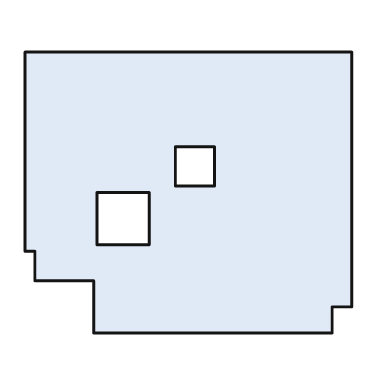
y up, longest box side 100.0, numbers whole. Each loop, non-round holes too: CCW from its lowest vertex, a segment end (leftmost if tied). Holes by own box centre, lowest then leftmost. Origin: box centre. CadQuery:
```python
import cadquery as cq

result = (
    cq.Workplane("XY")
    .moveTo(-29.0, -43.0)
    .lineTo(44.0, -43.0)
    .lineTo(44.0, -35.0)
    .lineTo(50.0, -35.0)
    .lineTo(50.0, 43.0)
    .lineTo(-50.0, 43.0)
    .lineTo(-50.0, -18.0)
    .lineTo(-47.0, -18.0)
    .lineTo(-47.0, -27.0)
    .lineTo(-29.0, -27.0)
    .close()
    .moveTo(-28.0, -16.0)
    .lineTo(-12.0, -16.0)
    .lineTo(-12.0, 0.0)
    .lineTo(-28.0, 0.0)
    .close()
    .moveTo(-4.0, 2.0)
    .lineTo(8.0, 2.0)
    .lineTo(8.0, 14.0)
    .lineTo(-4.0, 14.0)
    .close()
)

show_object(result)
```